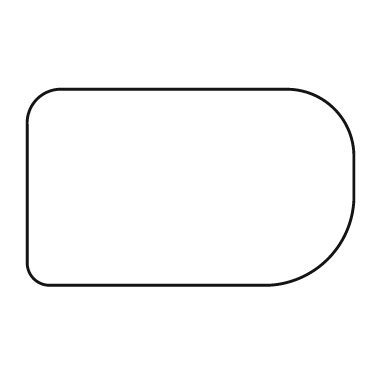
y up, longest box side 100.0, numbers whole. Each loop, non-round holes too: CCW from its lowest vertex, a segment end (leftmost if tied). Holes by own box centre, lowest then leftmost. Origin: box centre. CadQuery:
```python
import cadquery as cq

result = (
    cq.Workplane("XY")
    .moveTo(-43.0, -30.0)
    .lineTo(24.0, -30.0)
    .threePointArc((42.0, -22.0), (50.0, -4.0))
    .lineTo(50.0, 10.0)
    .threePointArc((44.0, 24.0), (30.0, 30.0))
    .lineTo(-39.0, 30.0)
    .threePointArc((-47.0, 27.0), (-50.0, 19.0))
    .lineTo(-50.0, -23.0)
    .threePointArc((-48.0, -28.0), (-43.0, -30.0))
    .close()
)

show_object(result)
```